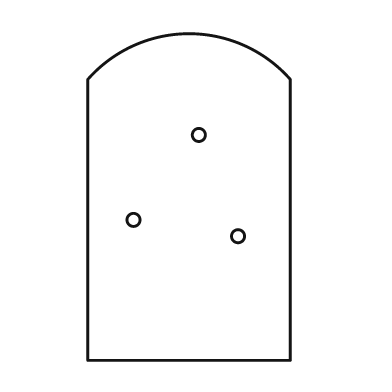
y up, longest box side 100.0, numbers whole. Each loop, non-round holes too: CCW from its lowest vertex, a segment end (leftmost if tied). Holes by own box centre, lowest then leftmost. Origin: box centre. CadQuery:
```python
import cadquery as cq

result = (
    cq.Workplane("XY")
    .moveTo(-31.0, -50.0)
    .lineTo(31.0, -50.0)
    .lineTo(31.0, 36.0)
    .threePointArc((0.0, 50.0), (-31.0, 36.0))
    .close()
    .moveTo(15.0, -12.0)
    .circle(2.0)
    .moveTo(-17.0, -7.0)
    .circle(2.0)
    .moveTo(3.0, 19.0)
    .circle(2.0)
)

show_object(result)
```